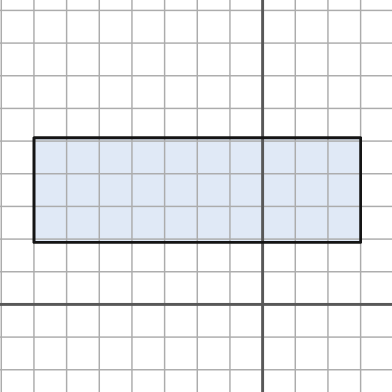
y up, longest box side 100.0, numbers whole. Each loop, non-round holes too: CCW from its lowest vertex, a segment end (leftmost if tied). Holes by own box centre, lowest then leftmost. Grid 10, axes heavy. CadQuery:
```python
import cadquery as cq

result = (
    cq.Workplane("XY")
    .moveTo(-70.0, 19.0)
    .lineTo(30.0, 19.0)
    .lineTo(30.0, 51.0)
    .lineTo(-70.0, 51.0)
    .close()
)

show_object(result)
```